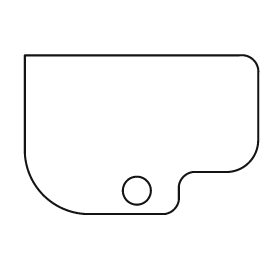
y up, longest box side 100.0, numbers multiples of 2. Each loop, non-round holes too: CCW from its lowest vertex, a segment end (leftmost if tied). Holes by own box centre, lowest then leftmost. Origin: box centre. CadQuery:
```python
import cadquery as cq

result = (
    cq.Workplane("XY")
    .moveTo(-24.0, -34.0)
    .lineTo(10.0, -34.0)
    .threePointArc((14.0, -32.0), (16.0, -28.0))
    .lineTo(16.0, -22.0)
    .threePointArc((18.0, -18.0), (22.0, -16.0))
    .lineTo(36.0, -16.0)
    .threePointArc((46.0, -12.0), (50.0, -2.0))
    .lineTo(50.0, 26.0)
    .threePointArc((48.0, 32.0), (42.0, 34.0))
    .lineTo(-50.0, 34.0)
    .lineTo(-50.0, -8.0)
    .threePointArc((-42.0, -26.0), (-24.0, -34.0))
    .close()
    .moveTo(-2.0, -24.0)
    .circle(6.0)
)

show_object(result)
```